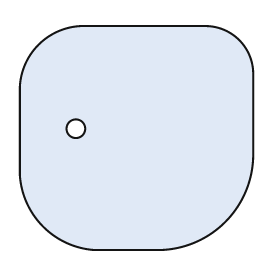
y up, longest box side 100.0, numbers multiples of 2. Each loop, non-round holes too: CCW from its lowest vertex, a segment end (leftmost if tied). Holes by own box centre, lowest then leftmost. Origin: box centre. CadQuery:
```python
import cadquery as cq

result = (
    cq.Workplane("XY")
    .moveTo(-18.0, -48.0)
    .lineTo(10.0, -48.0)
    .threePointArc((38.0, -36.0), (50.0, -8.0))
    .lineTo(50.0, 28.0)
    .threePointArc((44.0, 42.0), (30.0, 48.0))
    .lineTo(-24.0, 48.0)
    .threePointArc((-42.0, 40.0), (-50.0, 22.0))
    .lineTo(-50.0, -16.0)
    .threePointArc((-40.0, -38.0), (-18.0, -48.0))
    .close()
    .moveTo(-26.0, 4.0)
    .circle(4.0)
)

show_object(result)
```